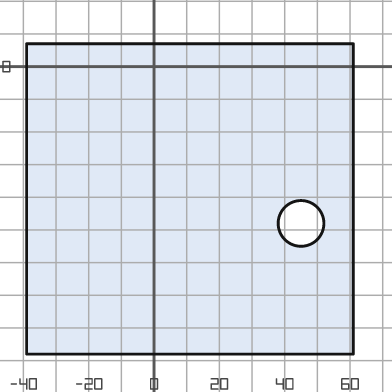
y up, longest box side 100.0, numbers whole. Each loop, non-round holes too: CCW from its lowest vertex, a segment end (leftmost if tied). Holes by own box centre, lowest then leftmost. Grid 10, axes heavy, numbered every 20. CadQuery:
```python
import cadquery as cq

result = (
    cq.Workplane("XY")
    .moveTo(-39.0, -88.0)
    .lineTo(61.0, -88.0)
    .lineTo(61.0, 7.0)
    .lineTo(-39.0, 7.0)
    .close()
    .moveTo(45.0, -48.0)
    .circle(7.0)
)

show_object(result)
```